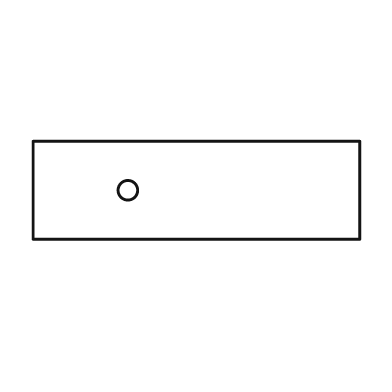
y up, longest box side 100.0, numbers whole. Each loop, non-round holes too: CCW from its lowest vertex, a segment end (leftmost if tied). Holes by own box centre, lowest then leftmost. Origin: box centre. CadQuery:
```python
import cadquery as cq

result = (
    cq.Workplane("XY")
    .moveTo(-50.0, -15.0)
    .lineTo(50.0, -15.0)
    .lineTo(50.0, 15.0)
    .lineTo(-50.0, 15.0)
    .close()
    .moveTo(-21.0, 0.0)
    .circle(3.0)
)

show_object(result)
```